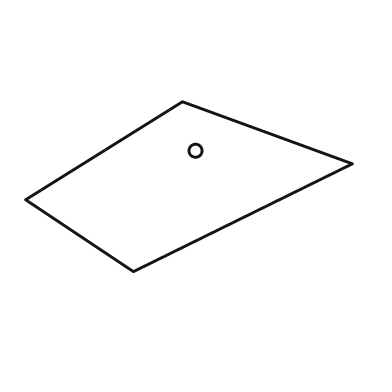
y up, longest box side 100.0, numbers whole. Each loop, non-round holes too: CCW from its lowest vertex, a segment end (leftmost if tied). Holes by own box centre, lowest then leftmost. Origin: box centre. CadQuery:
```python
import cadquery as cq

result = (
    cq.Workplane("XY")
    .moveTo(-17.0, -26.0)
    .lineTo(50.0, 7.0)
    .lineTo(-2.0, 26.0)
    .lineTo(-50.0, -4.0)
    .close()
    .moveTo(2.0, 11.0)
    .circle(2.0)
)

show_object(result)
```